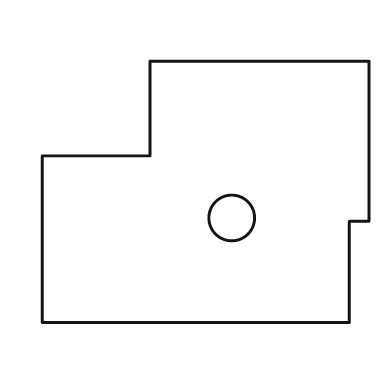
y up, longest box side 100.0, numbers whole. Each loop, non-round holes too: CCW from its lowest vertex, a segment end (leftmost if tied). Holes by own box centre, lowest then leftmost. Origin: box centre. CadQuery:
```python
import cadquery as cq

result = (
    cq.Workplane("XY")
    .moveTo(-50.0, -40.0)
    .lineTo(44.0, -40.0)
    .lineTo(44.0, -9.0)
    .lineTo(50.0, -9.0)
    .lineTo(50.0, 40.0)
    .lineTo(-17.0, 40.0)
    .lineTo(-17.0, 11.0)
    .lineTo(-50.0, 11.0)
    .close()
    .moveTo(8.0, -8.0)
    .circle(7.0)
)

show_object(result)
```